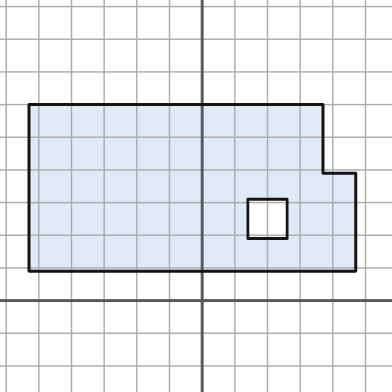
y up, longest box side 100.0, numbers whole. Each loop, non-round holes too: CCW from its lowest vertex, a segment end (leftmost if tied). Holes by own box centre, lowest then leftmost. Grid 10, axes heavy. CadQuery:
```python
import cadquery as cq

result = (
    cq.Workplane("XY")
    .moveTo(-53.0, 9.0)
    .lineTo(47.0, 9.0)
    .lineTo(47.0, 39.0)
    .lineTo(37.0, 39.0)
    .lineTo(37.0, 60.0)
    .lineTo(-53.0, 60.0)
    .close()
    .moveTo(14.0, 19.0)
    .lineTo(26.0, 19.0)
    .lineTo(26.0, 31.0)
    .lineTo(14.0, 31.0)
    .close()
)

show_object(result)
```